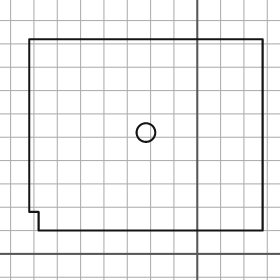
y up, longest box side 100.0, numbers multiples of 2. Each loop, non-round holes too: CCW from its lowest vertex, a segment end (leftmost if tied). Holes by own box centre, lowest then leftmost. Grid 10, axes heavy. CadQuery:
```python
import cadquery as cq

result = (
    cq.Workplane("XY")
    .moveTo(-68.0, 10.0)
    .lineTo(28.0, 10.0)
    .lineTo(28.0, 92.0)
    .lineTo(-72.0, 92.0)
    .lineTo(-72.0, 18.0)
    .lineTo(-68.0, 18.0)
    .close()
    .moveTo(-22.0, 52.0)
    .circle(4.0)
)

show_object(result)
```